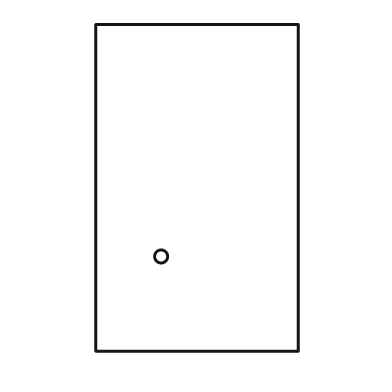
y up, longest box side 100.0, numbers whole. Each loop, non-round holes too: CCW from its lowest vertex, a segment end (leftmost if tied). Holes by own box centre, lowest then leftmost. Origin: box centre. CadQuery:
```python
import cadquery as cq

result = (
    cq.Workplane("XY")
    .moveTo(-31.0, -50.0)
    .lineTo(31.0, -50.0)
    .lineTo(31.0, 50.0)
    .lineTo(-31.0, 50.0)
    .close()
    .moveTo(-11.0, -21.0)
    .circle(2.0)
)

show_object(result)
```